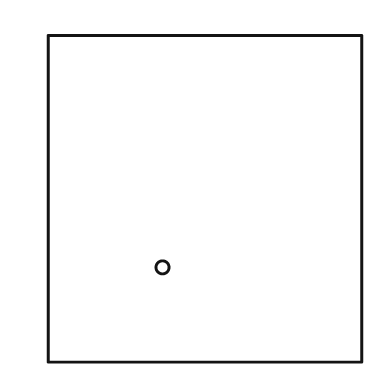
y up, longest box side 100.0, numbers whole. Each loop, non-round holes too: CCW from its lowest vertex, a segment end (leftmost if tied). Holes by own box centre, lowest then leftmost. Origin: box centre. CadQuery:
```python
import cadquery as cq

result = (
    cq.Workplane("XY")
    .moveTo(-48.0, -50.0)
    .lineTo(48.0, -50.0)
    .lineTo(48.0, 50.0)
    .lineTo(-48.0, 50.0)
    .close()
    .moveTo(-13.0, -21.0)
    .circle(2.0)
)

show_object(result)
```